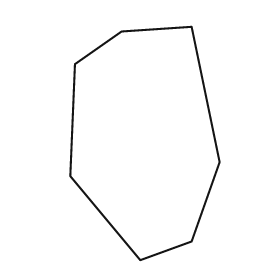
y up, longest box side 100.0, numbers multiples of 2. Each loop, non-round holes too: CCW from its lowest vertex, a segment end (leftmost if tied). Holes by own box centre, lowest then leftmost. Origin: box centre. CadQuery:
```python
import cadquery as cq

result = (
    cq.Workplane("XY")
    .moveTo(-2.0, -50.0)
    .lineTo(20.0, -42.0)
    .lineTo(32.0, -8.0)
    .lineTo(20.0, 50.0)
    .lineTo(-10.0, 48.0)
    .lineTo(-30.0, 34.0)
    .lineTo(-32.0, -14.0)
    .close()
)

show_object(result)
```